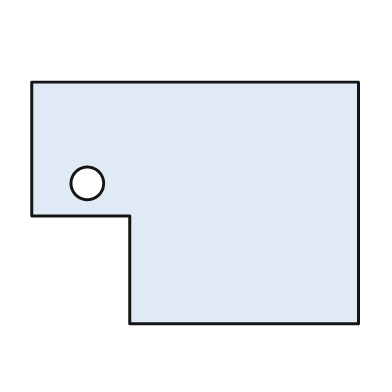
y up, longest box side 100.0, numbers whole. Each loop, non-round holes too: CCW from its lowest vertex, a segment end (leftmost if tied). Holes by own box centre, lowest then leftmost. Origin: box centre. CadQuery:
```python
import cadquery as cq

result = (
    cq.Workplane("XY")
    .moveTo(-20.0, -37.0)
    .lineTo(50.0, -37.0)
    .lineTo(50.0, 37.0)
    .lineTo(-50.0, 37.0)
    .lineTo(-50.0, -4.0)
    .lineTo(-20.0, -4.0)
    .close()
    .moveTo(-33.0, 6.0)
    .circle(5.0)
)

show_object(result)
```